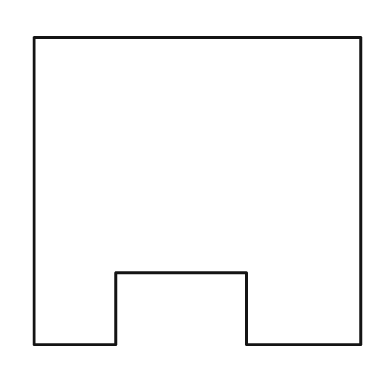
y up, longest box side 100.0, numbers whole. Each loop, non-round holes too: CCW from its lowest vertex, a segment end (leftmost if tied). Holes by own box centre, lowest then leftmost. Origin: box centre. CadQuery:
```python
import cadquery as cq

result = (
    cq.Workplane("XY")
    .moveTo(-50.0, -47.0)
    .lineTo(-25.0, -47.0)
    .lineTo(-25.0, -25.0)
    .lineTo(15.0, -25.0)
    .lineTo(15.0, -47.0)
    .lineTo(50.0, -47.0)
    .lineTo(50.0, 47.0)
    .lineTo(-50.0, 47.0)
    .close()
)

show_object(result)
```